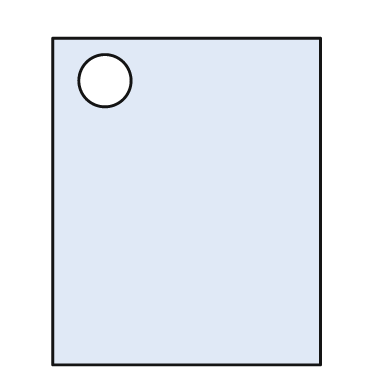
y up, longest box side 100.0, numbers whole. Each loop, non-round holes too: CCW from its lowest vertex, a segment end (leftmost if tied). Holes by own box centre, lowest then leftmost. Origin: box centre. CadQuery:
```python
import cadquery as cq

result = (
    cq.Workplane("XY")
    .moveTo(-41.0, -50.0)
    .lineTo(41.0, -50.0)
    .lineTo(41.0, 50.0)
    .lineTo(-41.0, 50.0)
    .close()
    .moveTo(-25.0, 37.0)
    .circle(8.0)
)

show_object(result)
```